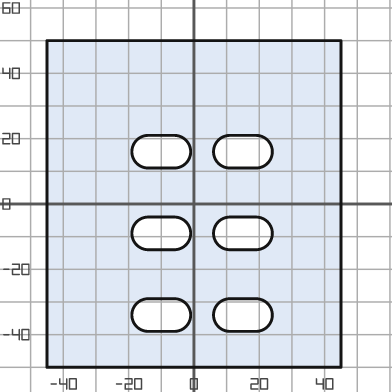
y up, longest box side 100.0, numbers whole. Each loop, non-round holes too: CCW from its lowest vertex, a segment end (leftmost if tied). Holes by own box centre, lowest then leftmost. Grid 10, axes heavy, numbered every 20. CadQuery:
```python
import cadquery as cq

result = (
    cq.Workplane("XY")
    .moveTo(-45.0, -50.0)
    .lineTo(45.0, -50.0)
    .lineTo(45.0, 50.0)
    .lineTo(-45.0, 50.0)
    .close()
    .moveTo(-14.0, -39.0)
    .lineTo(-6.0, -39.0)
    .threePointArc((-1.0, -34.0), (-6.0, -29.0))
    .lineTo(-14.0, -29.0)
    .threePointArc((-19.0, -34.0), (-14.0, -39.0))
    .close()
    .moveTo(11.0, -39.0)
    .lineTo(19.0, -39.0)
    .threePointArc((24.0, -34.0), (19.0, -29.0))
    .lineTo(11.0, -29.0)
    .threePointArc((6.0, -34.0), (11.0, -39.0))
    .close()
    .moveTo(-14.0, -14.0)
    .lineTo(-6.0, -14.0)
    .threePointArc((-1.0, -9.0), (-6.0, -4.0))
    .lineTo(-14.0, -4.0)
    .threePointArc((-19.0, -9.0), (-14.0, -14.0))
    .close()
    .moveTo(11.0, -14.0)
    .lineTo(19.0, -14.0)
    .threePointArc((24.0, -9.0), (19.0, -4.0))
    .lineTo(11.0, -4.0)
    .threePointArc((6.0, -9.0), (11.0, -14.0))
    .close()
    .moveTo(-14.0, 11.0)
    .lineTo(-6.0, 11.0)
    .threePointArc((-1.0, 16.0), (-6.0, 21.0))
    .lineTo(-14.0, 21.0)
    .threePointArc((-19.0, 16.0), (-14.0, 11.0))
    .close()
    .moveTo(11.0, 11.0)
    .lineTo(19.0, 11.0)
    .threePointArc((24.0, 16.0), (19.0, 21.0))
    .lineTo(11.0, 21.0)
    .threePointArc((6.0, 16.0), (11.0, 11.0))
    .close()
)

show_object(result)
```